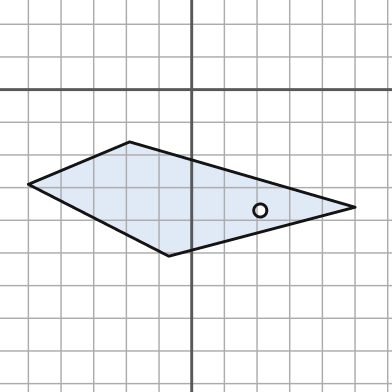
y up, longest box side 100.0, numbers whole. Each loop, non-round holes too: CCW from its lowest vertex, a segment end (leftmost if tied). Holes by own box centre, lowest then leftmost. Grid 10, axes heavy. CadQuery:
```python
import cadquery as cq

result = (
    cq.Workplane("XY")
    .moveTo(-7.0, -51.0)
    .lineTo(50.0, -36.0)
    .lineTo(-19.0, -16.0)
    .lineTo(-50.0, -29.0)
    .close()
    .moveTo(21.0, -37.0)
    .circle(2.0)
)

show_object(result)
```